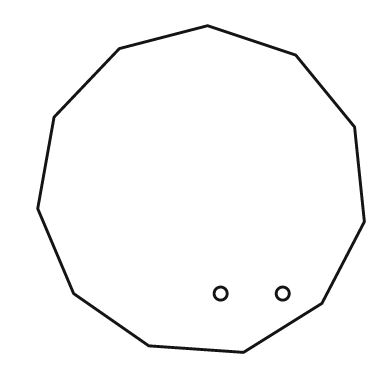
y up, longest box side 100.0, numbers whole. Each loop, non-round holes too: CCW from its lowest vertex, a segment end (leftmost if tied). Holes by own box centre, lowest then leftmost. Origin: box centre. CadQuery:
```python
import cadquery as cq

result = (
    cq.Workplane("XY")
    .moveTo(13.0, -50.0)
    .lineTo(37.0, -35.0)
    .lineTo(50.0, -10.0)
    .lineTo(47.0, 19.0)
    .lineTo(29.0, 41.0)
    .lineTo(2.0, 50.0)
    .lineTo(-25.0, 43.0)
    .lineTo(-45.0, 22.0)
    .lineTo(-50.0, -6.0)
    .lineTo(-39.0, -32.0)
    .lineTo(-16.0, -48.0)
    .close()
    .moveTo(6.0, -32.0)
    .circle(2.0)
    .moveTo(25.0, -32.0)
    .circle(2.0)
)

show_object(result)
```